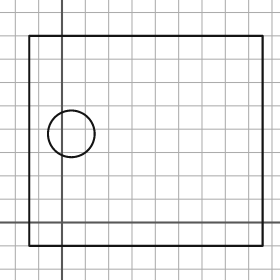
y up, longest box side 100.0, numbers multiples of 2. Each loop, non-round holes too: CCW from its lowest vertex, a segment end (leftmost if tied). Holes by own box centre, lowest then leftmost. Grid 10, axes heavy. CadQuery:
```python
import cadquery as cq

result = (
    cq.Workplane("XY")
    .moveTo(-14.0, -10.0)
    .lineTo(86.0, -10.0)
    .lineTo(86.0, 80.0)
    .lineTo(-14.0, 80.0)
    .close()
    .moveTo(4.0, 38.0)
    .circle(10.0)
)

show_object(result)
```